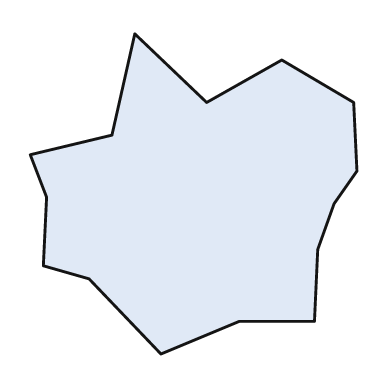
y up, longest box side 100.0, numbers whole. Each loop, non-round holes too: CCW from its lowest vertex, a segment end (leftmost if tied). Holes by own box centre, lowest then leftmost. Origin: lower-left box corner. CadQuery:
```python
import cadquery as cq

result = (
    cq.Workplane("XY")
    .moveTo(40.0, 0.0)
    .lineTo(64.0, 10.0)
    .lineTo(87.0, 10.0)
    .lineTo(88.0, 32.0)
    .lineTo(93.0, 46.0)
    .lineTo(100.0, 56.0)
    .lineTo(99.0, 77.0)
    .lineTo(77.0, 90.0)
    .lineTo(54.0, 77.0)
    .lineTo(32.0, 98.0)
    .lineTo(25.0, 67.0)
    .lineTo(0.0, 61.0)
    .lineTo(5.0, 48.0)
    .lineTo(4.0, 27.0)
    .lineTo(18.0, 23.0)
    .close()
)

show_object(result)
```